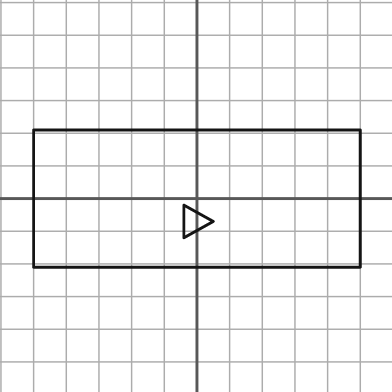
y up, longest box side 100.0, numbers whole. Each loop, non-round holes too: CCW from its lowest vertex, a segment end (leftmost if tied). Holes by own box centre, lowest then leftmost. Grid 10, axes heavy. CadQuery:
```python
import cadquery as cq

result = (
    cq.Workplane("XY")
    .moveTo(-50.0, -21.0)
    .lineTo(50.0, -21.0)
    .lineTo(50.0, 21.0)
    .lineTo(-50.0, 21.0)
    .close()
    .moveTo(-4.0, -12.0)
    .lineTo(5.0, -7.0)
    .lineTo(-4.0, -2.0)
    .close()
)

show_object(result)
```